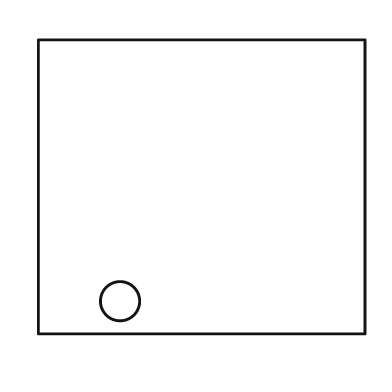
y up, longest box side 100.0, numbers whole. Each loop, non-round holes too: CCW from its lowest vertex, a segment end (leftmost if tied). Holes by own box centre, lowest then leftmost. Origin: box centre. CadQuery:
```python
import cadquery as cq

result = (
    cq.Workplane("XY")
    .moveTo(-50.0, -45.0)
    .lineTo(50.0, -45.0)
    .lineTo(50.0, 45.0)
    .lineTo(-50.0, 45.0)
    .close()
    .moveTo(-25.0, -35.0)
    .circle(6.0)
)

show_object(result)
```